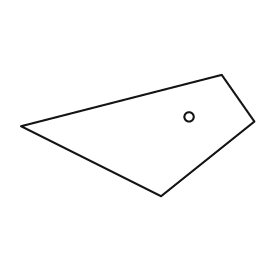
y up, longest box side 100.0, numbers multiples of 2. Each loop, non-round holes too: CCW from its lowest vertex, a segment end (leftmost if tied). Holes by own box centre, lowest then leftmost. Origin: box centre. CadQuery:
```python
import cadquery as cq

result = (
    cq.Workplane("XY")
    .moveTo(10.0, -26.0)
    .lineTo(50.0, 6.0)
    .lineTo(36.0, 26.0)
    .lineTo(-50.0, 4.0)
    .close()
    .moveTo(22.0, 8.0)
    .circle(2.0)
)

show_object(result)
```